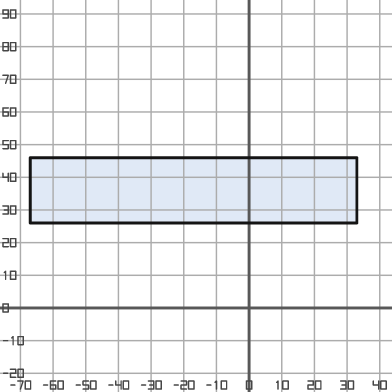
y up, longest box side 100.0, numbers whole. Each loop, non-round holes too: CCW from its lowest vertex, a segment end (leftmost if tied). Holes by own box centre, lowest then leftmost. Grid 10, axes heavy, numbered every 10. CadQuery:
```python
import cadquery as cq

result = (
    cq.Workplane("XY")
    .moveTo(-67.0, 26.0)
    .lineTo(33.0, 26.0)
    .lineTo(33.0, 46.0)
    .lineTo(-67.0, 46.0)
    .close()
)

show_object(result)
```